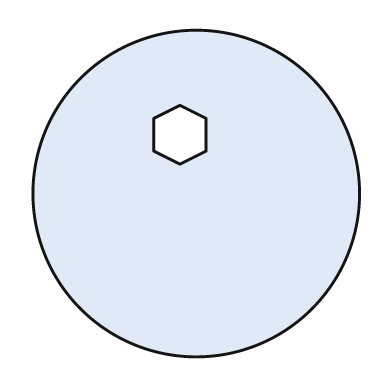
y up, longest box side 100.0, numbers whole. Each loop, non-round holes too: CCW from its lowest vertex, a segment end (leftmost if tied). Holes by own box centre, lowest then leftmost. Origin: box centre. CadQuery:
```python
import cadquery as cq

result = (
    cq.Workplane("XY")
    .moveTo(0.0, 0.0)
    .circle(50.0)
    .moveTo(-5.0, 9.0)
    .lineTo(3.0, 13.0)
    .lineTo(3.0, 23.0)
    .lineTo(-5.0, 27.0)
    .lineTo(-13.0, 23.0)
    .lineTo(-13.0, 13.0)
    .close()
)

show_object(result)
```